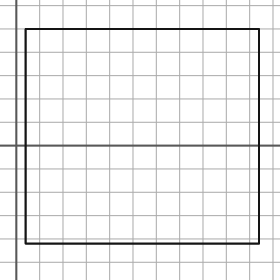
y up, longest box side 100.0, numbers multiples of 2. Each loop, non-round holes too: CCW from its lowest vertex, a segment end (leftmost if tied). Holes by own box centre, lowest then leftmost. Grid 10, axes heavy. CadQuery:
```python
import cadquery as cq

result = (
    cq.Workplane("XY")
    .moveTo(4.0, -42.0)
    .lineTo(104.0, -42.0)
    .lineTo(104.0, 50.0)
    .lineTo(4.0, 50.0)
    .close()
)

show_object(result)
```